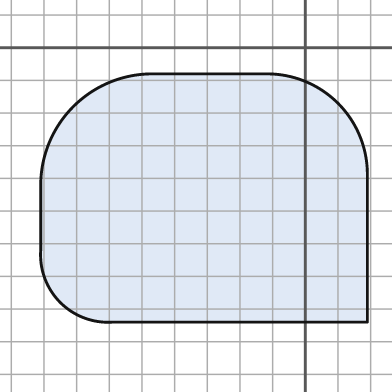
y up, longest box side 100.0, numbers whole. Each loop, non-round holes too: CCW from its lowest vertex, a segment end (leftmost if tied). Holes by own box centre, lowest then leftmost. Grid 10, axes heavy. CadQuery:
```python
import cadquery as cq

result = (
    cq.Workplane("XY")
    .moveTo(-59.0, -84.0)
    .lineTo(19.0, -84.0)
    .lineTo(19.0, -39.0)
    .threePointArc((10.0, -17.0), (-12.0, -8.0))
    .lineTo(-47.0, -8.0)
    .threePointArc((-71.0, -18.0), (-81.0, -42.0))
    .lineTo(-81.0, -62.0)
    .threePointArc((-75.0, -78.0), (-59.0, -84.0))
    .close()
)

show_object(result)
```